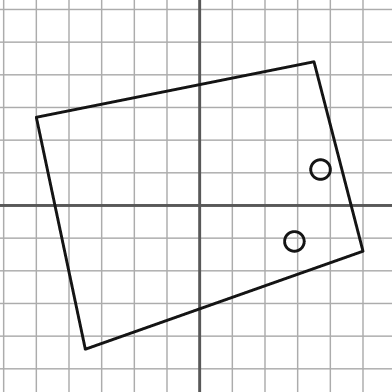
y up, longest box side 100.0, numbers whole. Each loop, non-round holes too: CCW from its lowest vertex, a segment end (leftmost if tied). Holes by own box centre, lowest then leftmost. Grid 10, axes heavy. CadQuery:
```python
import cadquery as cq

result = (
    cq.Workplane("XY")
    .moveTo(-35.0, -44.0)
    .lineTo(50.0, -14.0)
    .lineTo(35.0, 44.0)
    .lineTo(-50.0, 27.0)
    .close()
    .moveTo(29.0, -11.0)
    .circle(3.0)
    .moveTo(37.0, 11.0)
    .circle(3.0)
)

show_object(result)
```